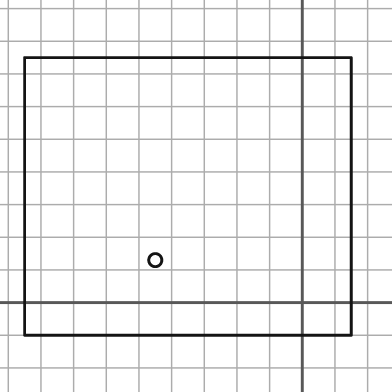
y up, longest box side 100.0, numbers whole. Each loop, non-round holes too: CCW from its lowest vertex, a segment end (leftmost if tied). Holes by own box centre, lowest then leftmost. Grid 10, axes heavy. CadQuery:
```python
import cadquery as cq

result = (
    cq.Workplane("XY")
    .moveTo(-85.0, -10.0)
    .lineTo(15.0, -10.0)
    .lineTo(15.0, 75.0)
    .lineTo(-85.0, 75.0)
    .close()
    .moveTo(-45.0, 13.0)
    .circle(2.0)
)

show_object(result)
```